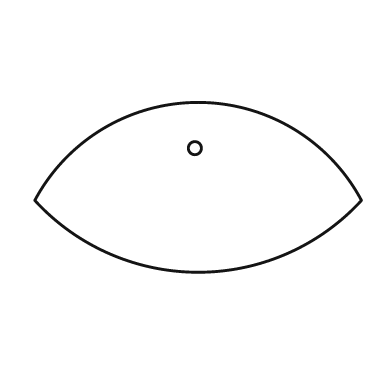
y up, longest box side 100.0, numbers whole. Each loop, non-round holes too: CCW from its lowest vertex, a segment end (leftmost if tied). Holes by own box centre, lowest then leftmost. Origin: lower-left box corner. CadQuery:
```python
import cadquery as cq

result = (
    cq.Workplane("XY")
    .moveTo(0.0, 22.0)
    .threePointArc((50.0, 0.0), (100.0, 22.0))
    .threePointArc((50.0, 52.0), (0.0, 22.0))
    .close()
    .moveTo(49.0, 38.0)
    .circle(2.0)
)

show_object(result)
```